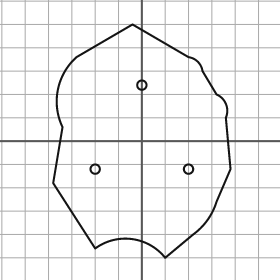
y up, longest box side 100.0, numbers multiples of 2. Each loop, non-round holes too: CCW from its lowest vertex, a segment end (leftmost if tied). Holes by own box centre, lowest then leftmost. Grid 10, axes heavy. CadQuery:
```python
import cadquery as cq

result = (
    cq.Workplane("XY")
    .moveTo(10.0, -50.0)
    .lineTo(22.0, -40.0)
    .threePointArc((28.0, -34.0), (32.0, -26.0))
    .lineTo(38.0, -12.0)
    .lineTo(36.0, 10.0)
    .threePointArc((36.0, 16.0), (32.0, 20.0))
    .lineTo(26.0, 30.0)
    .threePointArc((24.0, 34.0), (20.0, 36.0))
    .lineTo(-4.0, 50.0)
    .lineTo(-28.0, 36.0)
    .threePointArc((-36.0, 22.0), (-34.0, 6.0))
    .lineTo(-38.0, -18.0)
    .lineTo(-20.0, -46.0)
    .threePointArc((-4.0, -42.0), (10.0, -50.0))
    .close()
    .moveTo(-20.0, -12.0)
    .circle(2.0)
    .moveTo(20.0, -12.0)
    .circle(2.0)
    .moveTo(0.0, 24.0)
    .circle(2.0)
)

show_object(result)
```